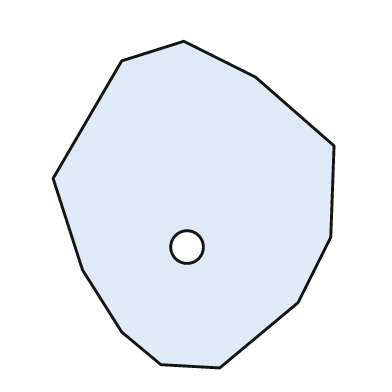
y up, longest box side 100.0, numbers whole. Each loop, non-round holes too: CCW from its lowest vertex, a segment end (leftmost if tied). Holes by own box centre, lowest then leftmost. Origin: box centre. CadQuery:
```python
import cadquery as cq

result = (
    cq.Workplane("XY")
    .moveTo(8.0, -50.0)
    .lineTo(32.0, -30.0)
    .lineTo(42.0, -10.0)
    .lineTo(43.0, 18.0)
    .lineTo(19.0, 39.0)
    .lineTo(-3.0, 50.0)
    .lineTo(-22.0, 44.0)
    .lineTo(-43.0, 8.0)
    .lineTo(-34.0, -20.0)
    .lineTo(-22.0, -39.0)
    .lineTo(-10.0, -49.0)
    .close()
    .moveTo(-2.0, -13.0)
    .circle(5.0)
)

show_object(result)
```